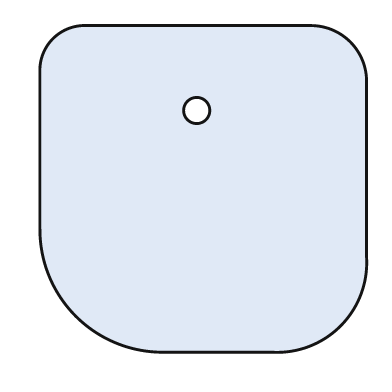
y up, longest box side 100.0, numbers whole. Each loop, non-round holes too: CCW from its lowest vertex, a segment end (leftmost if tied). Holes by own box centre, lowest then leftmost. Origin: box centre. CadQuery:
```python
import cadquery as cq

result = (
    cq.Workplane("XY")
    .moveTo(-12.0, -50.0)
    .lineTo(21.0, -50.0)
    .threePointArc((42.0, -42.0), (50.0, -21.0))
    .lineTo(50.0, 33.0)
    .threePointArc((45.0, 45.0), (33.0, 50.0))
    .lineTo(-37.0, 50.0)
    .threePointArc((-46.0, 46.0), (-50.0, 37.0))
    .lineTo(-50.0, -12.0)
    .threePointArc((-39.0, -39.0), (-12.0, -50.0))
    .close()
    .moveTo(-2.0, 24.0)
    .circle(4.0)
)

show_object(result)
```